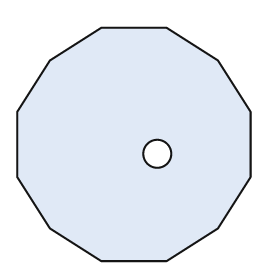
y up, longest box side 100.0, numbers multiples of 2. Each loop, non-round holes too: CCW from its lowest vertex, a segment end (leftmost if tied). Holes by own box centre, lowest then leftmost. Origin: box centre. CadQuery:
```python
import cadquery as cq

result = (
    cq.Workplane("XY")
    .moveTo(-14.0, -50.0)
    .lineTo(14.0, -50.0)
    .lineTo(36.0, -36.0)
    .lineTo(50.0, -14.0)
    .lineTo(50.0, 14.0)
    .lineTo(36.0, 36.0)
    .lineTo(14.0, 50.0)
    .lineTo(-14.0, 50.0)
    .lineTo(-36.0, 36.0)
    .lineTo(-50.0, 14.0)
    .lineTo(-50.0, -14.0)
    .lineTo(-36.0, -36.0)
    .close()
    .moveTo(10.0, -4.0)
    .circle(6.0)
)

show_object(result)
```